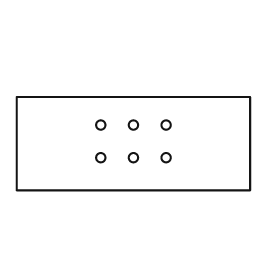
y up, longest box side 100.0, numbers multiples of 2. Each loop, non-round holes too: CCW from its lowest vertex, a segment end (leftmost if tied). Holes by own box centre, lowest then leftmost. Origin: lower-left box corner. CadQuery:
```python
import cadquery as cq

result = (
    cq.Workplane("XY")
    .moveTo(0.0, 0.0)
    .lineTo(100.0, 0.0)
    .lineTo(100.0, 40.0)
    .lineTo(0.0, 40.0)
    .close()
    .moveTo(36.0, 14.0)
    .circle(2.0)
    .moveTo(50.0, 14.0)
    .circle(2.0)
    .moveTo(64.0, 14.0)
    .circle(2.0)
    .moveTo(36.0, 28.0)
    .circle(2.0)
    .moveTo(50.0, 28.0)
    .circle(2.0)
    .moveTo(64.0, 28.0)
    .circle(2.0)
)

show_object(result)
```